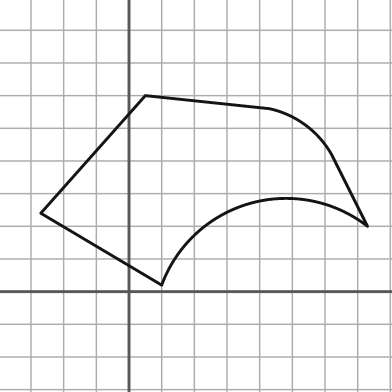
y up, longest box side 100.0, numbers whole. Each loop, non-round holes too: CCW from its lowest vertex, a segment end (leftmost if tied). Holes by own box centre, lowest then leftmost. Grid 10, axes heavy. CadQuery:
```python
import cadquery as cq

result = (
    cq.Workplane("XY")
    .moveTo(10.0, 2.0)
    .threePointArc((37.0, 27.0), (73.0, 20.0))
    .lineTo(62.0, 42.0)
    .threePointArc((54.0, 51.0), (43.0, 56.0))
    .lineTo(5.0, 60.0)
    .lineTo(-27.0, 24.0)
    .close()
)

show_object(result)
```